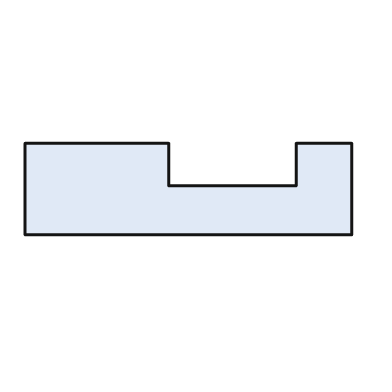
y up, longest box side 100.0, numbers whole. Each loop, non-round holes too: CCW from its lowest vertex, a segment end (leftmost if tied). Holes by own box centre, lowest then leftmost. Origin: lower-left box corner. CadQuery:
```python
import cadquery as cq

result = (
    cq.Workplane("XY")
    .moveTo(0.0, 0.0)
    .lineTo(100.0, 0.0)
    .lineTo(100.0, 28.0)
    .lineTo(83.0, 28.0)
    .lineTo(83.0, 15.0)
    .lineTo(44.0, 15.0)
    .lineTo(44.0, 28.0)
    .lineTo(0.0, 28.0)
    .close()
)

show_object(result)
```